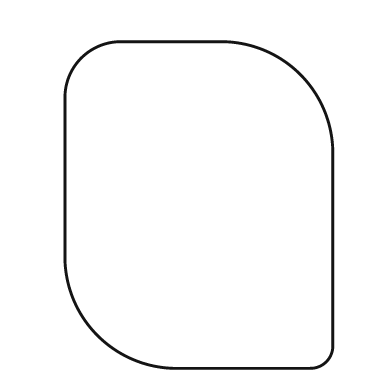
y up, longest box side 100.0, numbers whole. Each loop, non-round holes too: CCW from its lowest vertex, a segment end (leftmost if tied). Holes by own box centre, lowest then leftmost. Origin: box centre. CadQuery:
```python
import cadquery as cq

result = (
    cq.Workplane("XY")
    .moveTo(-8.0, -50.0)
    .lineTo(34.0, -50.0)
    .threePointArc((39.0, -48.0), (41.0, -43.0))
    .lineTo(41.0, 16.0)
    .threePointArc((31.0, 40.0), (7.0, 50.0))
    .lineTo(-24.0, 50.0)
    .threePointArc((-36.0, 45.0), (-41.0, 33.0))
    .lineTo(-41.0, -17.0)
    .threePointArc((-31.0, -40.0), (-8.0, -50.0))
    .close()
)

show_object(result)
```